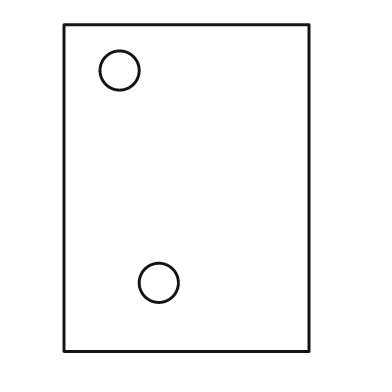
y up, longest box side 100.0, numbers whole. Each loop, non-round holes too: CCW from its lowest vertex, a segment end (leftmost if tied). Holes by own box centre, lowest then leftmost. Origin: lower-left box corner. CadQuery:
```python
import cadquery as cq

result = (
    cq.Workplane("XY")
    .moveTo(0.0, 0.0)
    .lineTo(75.0, 0.0)
    .lineTo(75.0, 100.0)
    .lineTo(0.0, 100.0)
    .close()
    .moveTo(29.0, 21.0)
    .circle(6.0)
    .moveTo(17.0, 86.0)
    .circle(6.0)
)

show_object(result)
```